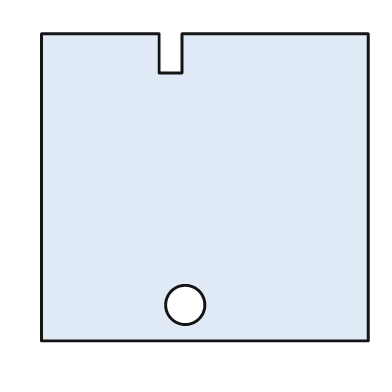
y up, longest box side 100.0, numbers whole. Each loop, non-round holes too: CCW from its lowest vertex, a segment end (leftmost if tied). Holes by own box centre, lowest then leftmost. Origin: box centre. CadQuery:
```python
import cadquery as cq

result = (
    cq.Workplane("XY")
    .moveTo(-50.0, -47.0)
    .lineTo(50.0, -47.0)
    .lineTo(50.0, 47.0)
    .lineTo(-7.0, 47.0)
    .lineTo(-7.0, 35.0)
    .lineTo(-14.0, 35.0)
    .lineTo(-14.0, 47.0)
    .lineTo(-50.0, 47.0)
    .close()
    .moveTo(-6.0, -36.0)
    .circle(6.0)
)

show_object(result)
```